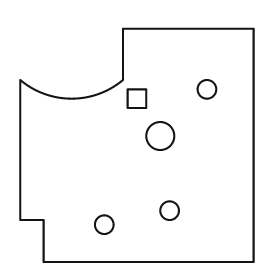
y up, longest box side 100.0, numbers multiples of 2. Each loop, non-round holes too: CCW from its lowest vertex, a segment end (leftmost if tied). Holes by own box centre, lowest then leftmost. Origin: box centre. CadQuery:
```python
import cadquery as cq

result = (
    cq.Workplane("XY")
    .moveTo(-40.0, -50.0)
    .lineTo(50.0, -50.0)
    .lineTo(50.0, 50.0)
    .lineTo(-6.0, 50.0)
    .lineTo(-6.0, 28.0)
    .threePointArc((-28.0, 20.0), (-50.0, 28.0))
    .lineTo(-50.0, -32.0)
    .lineTo(-40.0, -32.0)
    .close()
    .moveTo(-14.0, -34.0)
    .circle(4.0)
    .moveTo(14.0, -28.0)
    .circle(4.0)
    .moveTo(10.0, 4.0)
    .circle(6.0)
    .moveTo(-4.0, 16.0)
    .lineTo(4.0, 16.0)
    .lineTo(4.0, 24.0)
    .lineTo(-4.0, 24.0)
    .close()
    .moveTo(30.0, 24.0)
    .circle(4.0)
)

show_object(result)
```